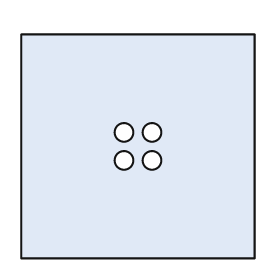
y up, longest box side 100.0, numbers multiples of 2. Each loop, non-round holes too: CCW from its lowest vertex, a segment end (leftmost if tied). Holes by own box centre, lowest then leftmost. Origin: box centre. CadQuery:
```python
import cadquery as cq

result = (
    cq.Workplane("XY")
    .moveTo(-50.0, -48.0)
    .lineTo(50.0, -48.0)
    .lineTo(50.0, 48.0)
    .lineTo(-50.0, 48.0)
    .close()
    .moveTo(-6.0, -6.0)
    .circle(4.0)
    .moveTo(6.0, -6.0)
    .circle(4.0)
    .moveTo(-6.0, 6.0)
    .circle(4.0)
    .moveTo(6.0, 6.0)
    .circle(4.0)
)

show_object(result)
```